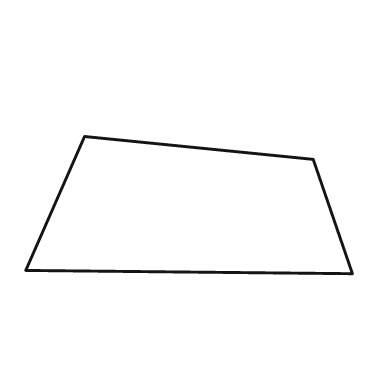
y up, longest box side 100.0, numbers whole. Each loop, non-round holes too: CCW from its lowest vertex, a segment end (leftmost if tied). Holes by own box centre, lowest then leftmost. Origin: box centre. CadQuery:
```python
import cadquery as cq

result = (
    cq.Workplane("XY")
    .moveTo(50.0, -21.0)
    .lineTo(38.0, 14.0)
    .lineTo(-32.0, 21.0)
    .lineTo(-50.0, -20.0)
    .close()
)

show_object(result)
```